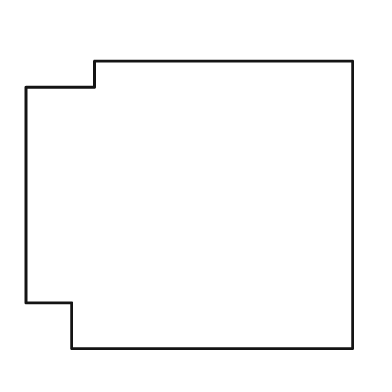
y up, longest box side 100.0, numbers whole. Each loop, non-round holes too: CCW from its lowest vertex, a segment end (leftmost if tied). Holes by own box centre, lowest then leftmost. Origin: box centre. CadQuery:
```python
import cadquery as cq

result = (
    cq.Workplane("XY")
    .moveTo(-36.0, -44.0)
    .lineTo(50.0, -44.0)
    .lineTo(50.0, 44.0)
    .lineTo(-29.0, 44.0)
    .lineTo(-29.0, 36.0)
    .lineTo(-50.0, 36.0)
    .lineTo(-50.0, -30.0)
    .lineTo(-36.0, -30.0)
    .close()
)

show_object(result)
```